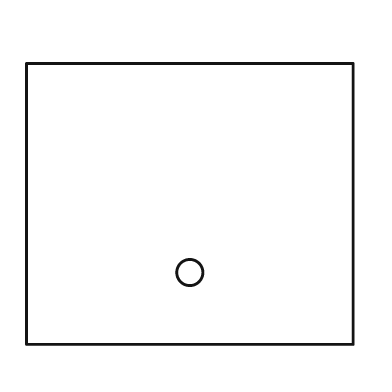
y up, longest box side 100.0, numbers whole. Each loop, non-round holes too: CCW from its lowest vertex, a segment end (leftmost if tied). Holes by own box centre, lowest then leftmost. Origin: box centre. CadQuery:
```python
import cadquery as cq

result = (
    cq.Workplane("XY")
    .moveTo(-50.0, -43.0)
    .lineTo(50.0, -43.0)
    .lineTo(50.0, 43.0)
    .lineTo(-50.0, 43.0)
    .close()
    .moveTo(0.0, -21.0)
    .circle(4.0)
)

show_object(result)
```